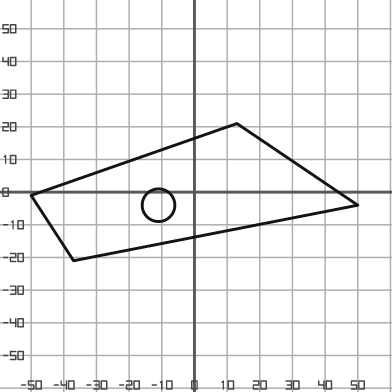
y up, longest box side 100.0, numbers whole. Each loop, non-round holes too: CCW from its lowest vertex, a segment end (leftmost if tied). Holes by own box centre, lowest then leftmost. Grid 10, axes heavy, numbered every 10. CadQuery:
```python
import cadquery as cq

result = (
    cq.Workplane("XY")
    .moveTo(-37.0, -21.0)
    .lineTo(50.0, -4.0)
    .lineTo(13.0, 21.0)
    .lineTo(-50.0, -1.0)
    .close()
    .moveTo(-11.0, -4.0)
    .circle(5.0)
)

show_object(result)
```